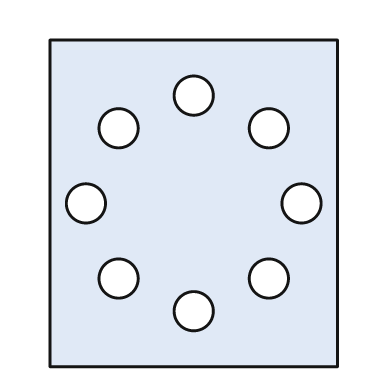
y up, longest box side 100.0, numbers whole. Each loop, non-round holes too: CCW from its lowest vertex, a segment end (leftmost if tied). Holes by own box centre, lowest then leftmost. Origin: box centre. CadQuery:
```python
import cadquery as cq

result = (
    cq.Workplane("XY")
    .moveTo(-44.0, -50.0)
    .lineTo(44.0, -50.0)
    .lineTo(44.0, 50.0)
    .lineTo(-44.0, 50.0)
    .close()
    .moveTo(0.0, -33.0)
    .circle(6.0)
    .moveTo(-23.0, -23.0)
    .circle(6.0)
    .moveTo(23.0, -23.0)
    .circle(6.0)
    .moveTo(-33.0, 0.0)
    .circle(6.0)
    .moveTo(33.0, 0.0)
    .circle(6.0)
    .moveTo(-23.0, 23.0)
    .circle(6.0)
    .moveTo(23.0, 23.0)
    .circle(6.0)
    .moveTo(0.0, 33.0)
    .circle(6.0)
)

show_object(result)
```